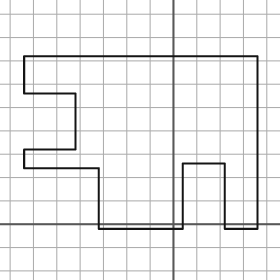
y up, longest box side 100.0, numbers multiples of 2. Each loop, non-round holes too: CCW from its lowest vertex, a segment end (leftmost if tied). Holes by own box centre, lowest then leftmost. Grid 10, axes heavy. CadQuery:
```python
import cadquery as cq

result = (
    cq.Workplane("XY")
    .moveTo(-32.0, -2.0)
    .lineTo(4.0, -2.0)
    .lineTo(4.0, 26.0)
    .lineTo(22.0, 26.0)
    .lineTo(22.0, -2.0)
    .lineTo(36.0, -2.0)
    .lineTo(36.0, 72.0)
    .lineTo(-64.0, 72.0)
    .lineTo(-64.0, 56.0)
    .lineTo(-42.0, 56.0)
    .lineTo(-42.0, 32.0)
    .lineTo(-64.0, 32.0)
    .lineTo(-64.0, 24.0)
    .lineTo(-32.0, 24.0)
    .close()
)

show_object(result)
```